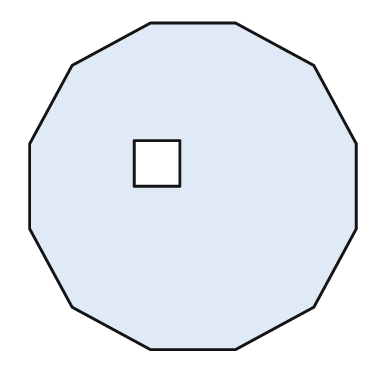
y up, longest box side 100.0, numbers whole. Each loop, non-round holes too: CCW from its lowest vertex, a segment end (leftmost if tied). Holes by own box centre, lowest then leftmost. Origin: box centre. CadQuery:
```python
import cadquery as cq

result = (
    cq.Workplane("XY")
    .moveTo(-13.0, -50.0)
    .lineTo(13.0, -50.0)
    .lineTo(37.0, -37.0)
    .lineTo(50.0, -13.0)
    .lineTo(50.0, 13.0)
    .lineTo(37.0, 37.0)
    .lineTo(13.0, 50.0)
    .lineTo(-13.0, 50.0)
    .lineTo(-37.0, 37.0)
    .lineTo(-50.0, 13.0)
    .lineTo(-50.0, -13.0)
    .lineTo(-37.0, -37.0)
    .close()
    .moveTo(-18.0, 0.0)
    .lineTo(-4.0, 0.0)
    .lineTo(-4.0, 14.0)
    .lineTo(-18.0, 14.0)
    .close()
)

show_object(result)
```